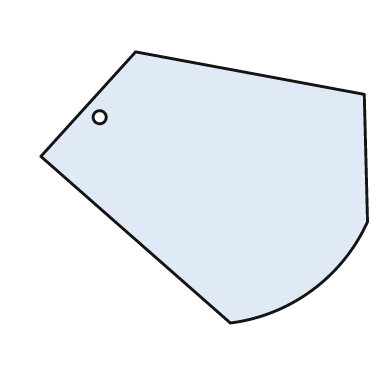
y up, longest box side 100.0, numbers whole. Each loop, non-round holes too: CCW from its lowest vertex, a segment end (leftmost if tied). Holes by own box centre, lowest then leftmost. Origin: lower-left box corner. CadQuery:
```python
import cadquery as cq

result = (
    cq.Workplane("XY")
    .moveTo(58.0, 0.0)
    .threePointArc((83.0, 10.0), (100.0, 31.0))
    .lineTo(99.0, 70.0)
    .lineTo(29.0, 83.0)
    .lineTo(0.0, 51.0)
    .close()
    .moveTo(18.0, 63.0)
    .circle(2.0)
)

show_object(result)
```